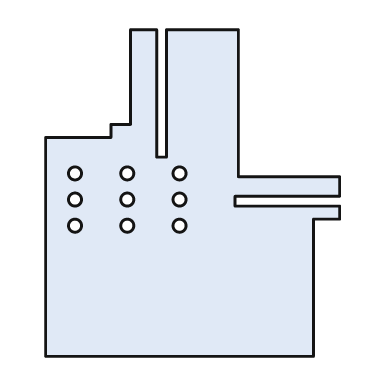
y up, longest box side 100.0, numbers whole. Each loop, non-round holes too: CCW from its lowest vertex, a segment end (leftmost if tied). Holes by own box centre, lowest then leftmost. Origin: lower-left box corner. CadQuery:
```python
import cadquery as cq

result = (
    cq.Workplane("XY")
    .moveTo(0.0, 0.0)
    .lineTo(82.0, 0.0)
    .lineTo(82.0, 42.0)
    .lineTo(90.0, 42.0)
    .lineTo(90.0, 46.0)
    .lineTo(58.0, 46.0)
    .lineTo(58.0, 49.0)
    .lineTo(90.0, 49.0)
    .lineTo(90.0, 55.0)
    .lineTo(59.0, 55.0)
    .lineTo(59.0, 100.0)
    .lineTo(37.0, 100.0)
    .lineTo(37.0, 61.0)
    .lineTo(34.0, 61.0)
    .lineTo(34.0, 100.0)
    .lineTo(26.0, 100.0)
    .lineTo(26.0, 71.0)
    .lineTo(20.0, 71.0)
    .lineTo(20.0, 67.0)
    .lineTo(0.0, 67.0)
    .close()
    .moveTo(9.0, 40.0)
    .circle(2.0)
    .moveTo(25.0, 40.0)
    .circle(2.0)
    .moveTo(41.0, 40.0)
    .circle(2.0)
    .moveTo(9.0, 48.0)
    .circle(2.0)
    .moveTo(25.0, 48.0)
    .circle(2.0)
    .moveTo(41.0, 48.0)
    .circle(2.0)
    .moveTo(9.0, 56.0)
    .circle(2.0)
    .moveTo(25.0, 56.0)
    .circle(2.0)
    .moveTo(41.0, 56.0)
    .circle(2.0)
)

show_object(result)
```